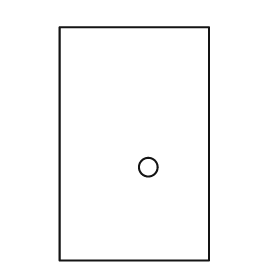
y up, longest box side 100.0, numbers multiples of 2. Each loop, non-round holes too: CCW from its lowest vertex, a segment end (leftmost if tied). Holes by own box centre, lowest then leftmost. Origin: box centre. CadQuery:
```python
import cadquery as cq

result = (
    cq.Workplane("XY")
    .moveTo(-32.0, -50.0)
    .lineTo(32.0, -50.0)
    .lineTo(32.0, 50.0)
    .lineTo(-32.0, 50.0)
    .close()
    .moveTo(6.0, -10.0)
    .circle(4.0)
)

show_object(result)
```